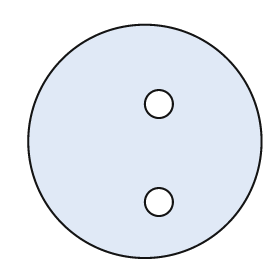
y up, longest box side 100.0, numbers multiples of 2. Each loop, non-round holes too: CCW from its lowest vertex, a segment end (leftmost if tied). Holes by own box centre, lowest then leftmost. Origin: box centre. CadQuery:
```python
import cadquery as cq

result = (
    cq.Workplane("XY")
    .moveTo(0.0, 0.0)
    .circle(50.0)
    .moveTo(6.0, -26.0)
    .circle(6.0)
    .moveTo(6.0, 16.0)
    .circle(6.0)
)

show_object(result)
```